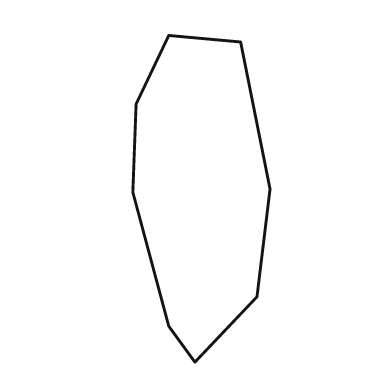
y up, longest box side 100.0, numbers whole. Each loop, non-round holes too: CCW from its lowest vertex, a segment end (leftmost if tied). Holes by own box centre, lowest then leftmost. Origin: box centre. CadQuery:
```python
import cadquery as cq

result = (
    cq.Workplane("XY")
    .moveTo(-2.0, -50.0)
    .lineTo(17.0, -30.0)
    .lineTo(21.0, 3.0)
    .lineTo(12.0, 48.0)
    .lineTo(-10.0, 50.0)
    .lineTo(-20.0, 29.0)
    .lineTo(-21.0, 2.0)
    .lineTo(-10.0, -39.0)
    .close()
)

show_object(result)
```